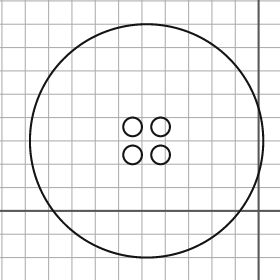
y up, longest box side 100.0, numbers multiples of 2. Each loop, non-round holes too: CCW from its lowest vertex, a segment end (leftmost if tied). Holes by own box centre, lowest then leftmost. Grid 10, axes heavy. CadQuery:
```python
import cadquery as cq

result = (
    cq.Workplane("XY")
    .moveTo(-48.0, 30.0)
    .circle(50.0)
    .moveTo(-54.0, 24.0)
    .circle(4.0)
    .moveTo(-42.0, 24.0)
    .circle(4.0)
    .moveTo(-54.0, 36.0)
    .circle(4.0)
    .moveTo(-42.0, 36.0)
    .circle(4.0)
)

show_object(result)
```